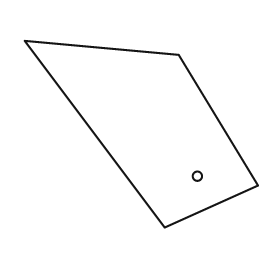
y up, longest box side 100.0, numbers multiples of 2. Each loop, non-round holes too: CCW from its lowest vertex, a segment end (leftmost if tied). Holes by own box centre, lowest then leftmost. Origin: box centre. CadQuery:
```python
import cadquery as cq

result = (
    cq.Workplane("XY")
    .moveTo(10.0, -40.0)
    .lineTo(50.0, -22.0)
    .lineTo(16.0, 34.0)
    .lineTo(-50.0, 40.0)
    .close()
    .moveTo(24.0, -18.0)
    .circle(2.0)
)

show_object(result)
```